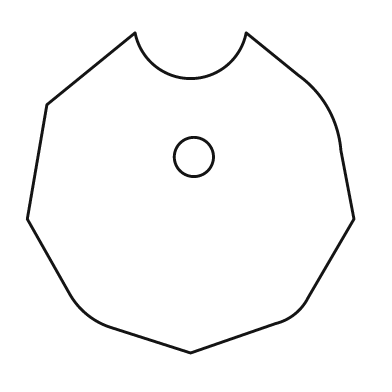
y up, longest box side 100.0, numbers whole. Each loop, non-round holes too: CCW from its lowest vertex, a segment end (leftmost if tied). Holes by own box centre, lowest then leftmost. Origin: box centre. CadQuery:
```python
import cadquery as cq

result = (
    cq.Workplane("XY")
    .moveTo(0.0, -49.0)
    .lineTo(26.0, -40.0)
    .threePointArc((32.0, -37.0), (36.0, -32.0))
    .lineTo(50.0, -8.0)
    .lineTo(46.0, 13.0)
    .threePointArc((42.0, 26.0), (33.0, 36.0))
    .lineTo(17.0, 49.0)
    .threePointArc((0.0, 35.0), (-17.0, 49.0))
    .lineTo(-44.0, 27.0)
    .lineTo(-50.0, -8.0)
    .lineTo(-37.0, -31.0)
    .threePointArc((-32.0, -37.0), (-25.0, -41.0))
    .close()
    .moveTo(1.0, 11.0)
    .circle(6.0)
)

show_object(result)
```